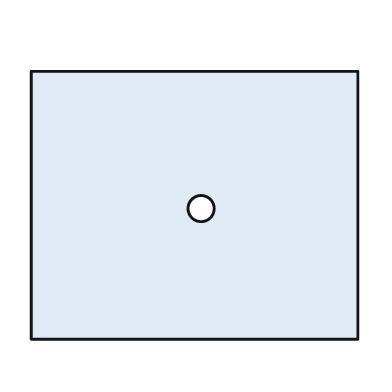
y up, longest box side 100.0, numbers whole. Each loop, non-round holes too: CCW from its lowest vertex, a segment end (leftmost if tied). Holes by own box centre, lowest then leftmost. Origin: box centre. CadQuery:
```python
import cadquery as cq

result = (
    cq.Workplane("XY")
    .moveTo(-50.0, -41.0)
    .lineTo(50.0, -41.0)
    .lineTo(50.0, 41.0)
    .lineTo(-50.0, 41.0)
    .close()
    .moveTo(2.0, -1.0)
    .circle(4.0)
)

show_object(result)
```